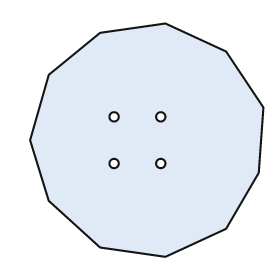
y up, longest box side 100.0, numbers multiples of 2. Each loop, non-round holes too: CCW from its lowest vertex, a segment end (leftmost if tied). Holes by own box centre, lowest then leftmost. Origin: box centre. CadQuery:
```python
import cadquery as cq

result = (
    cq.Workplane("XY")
    .moveTo(8.0, -50.0)
    .lineTo(34.0, -38.0)
    .lineTo(48.0, -14.0)
    .lineTo(50.0, 14.0)
    .lineTo(34.0, 38.0)
    .lineTo(8.0, 50.0)
    .lineTo(-20.0, 46.0)
    .lineTo(-42.0, 28.0)
    .lineTo(-50.0, 0.0)
    .lineTo(-42.0, -26.0)
    .lineTo(-20.0, -46.0)
    .close()
    .moveTo(-14.0, -10.0)
    .circle(2.0)
    .moveTo(6.0, -10.0)
    .circle(2.0)
    .moveTo(-14.0, 10.0)
    .circle(2.0)
    .moveTo(6.0, 10.0)
    .circle(2.0)
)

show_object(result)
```